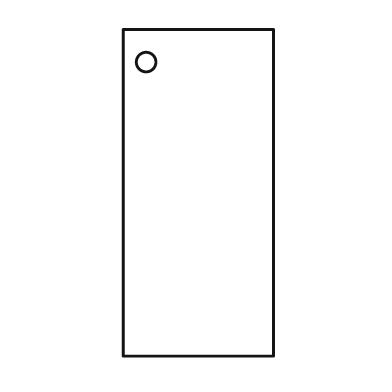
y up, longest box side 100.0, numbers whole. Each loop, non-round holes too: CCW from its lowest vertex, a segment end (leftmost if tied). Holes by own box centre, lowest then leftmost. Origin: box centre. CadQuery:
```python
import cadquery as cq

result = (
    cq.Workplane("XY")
    .moveTo(-23.0, -50.0)
    .lineTo(23.0, -50.0)
    .lineTo(23.0, 50.0)
    .lineTo(-23.0, 50.0)
    .close()
    .moveTo(-16.0, 40.0)
    .circle(3.0)
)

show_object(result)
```